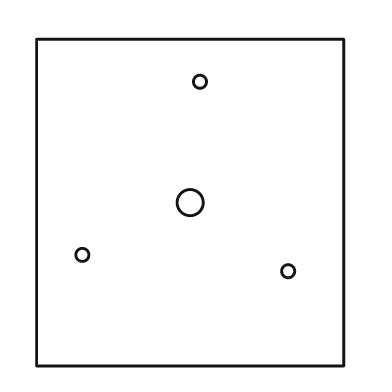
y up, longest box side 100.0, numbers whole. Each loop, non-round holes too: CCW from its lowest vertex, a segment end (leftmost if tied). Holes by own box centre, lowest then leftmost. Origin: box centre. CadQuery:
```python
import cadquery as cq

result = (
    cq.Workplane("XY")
    .moveTo(-47.0, -50.0)
    .lineTo(47.0, -50.0)
    .lineTo(47.0, 50.0)
    .lineTo(-47.0, 50.0)
    .close()
    .moveTo(30.0, -21.0)
    .circle(2.0)
    .moveTo(-33.0, -16.0)
    .circle(2.0)
    .moveTo(0.0, 0.0)
    .circle(4.0)
    .moveTo(3.0, 37.0)
    .circle(2.0)
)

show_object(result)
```